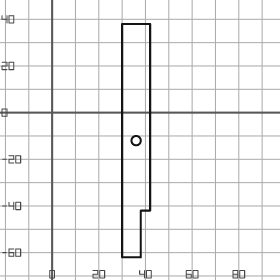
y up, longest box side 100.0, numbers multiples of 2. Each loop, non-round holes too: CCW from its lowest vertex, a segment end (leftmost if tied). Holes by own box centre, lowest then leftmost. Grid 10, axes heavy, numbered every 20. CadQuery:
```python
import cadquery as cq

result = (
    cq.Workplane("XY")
    .moveTo(30.0, -62.0)
    .lineTo(38.0, -62.0)
    .lineTo(38.0, -42.0)
    .lineTo(42.0, -42.0)
    .lineTo(42.0, 38.0)
    .lineTo(30.0, 38.0)
    .close()
    .moveTo(36.0, -12.0)
    .circle(2.0)
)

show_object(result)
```